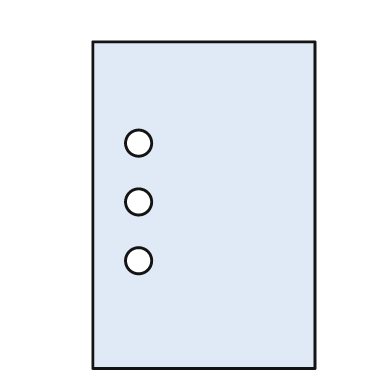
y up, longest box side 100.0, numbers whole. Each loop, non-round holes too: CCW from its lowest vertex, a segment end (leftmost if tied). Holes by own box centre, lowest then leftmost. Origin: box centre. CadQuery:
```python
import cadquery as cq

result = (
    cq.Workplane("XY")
    .moveTo(-34.0, -50.0)
    .lineTo(34.0, -50.0)
    .lineTo(34.0, 50.0)
    .lineTo(-34.0, 50.0)
    .close()
    .moveTo(-20.0, -17.0)
    .circle(4.0)
    .moveTo(-20.0, 1.0)
    .circle(4.0)
    .moveTo(-20.0, 19.0)
    .circle(4.0)
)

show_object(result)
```